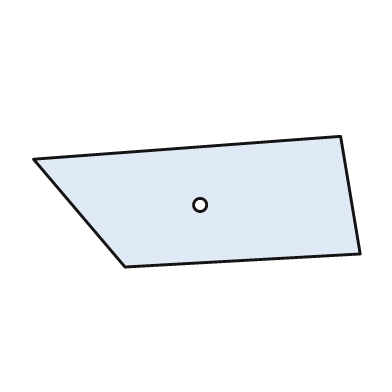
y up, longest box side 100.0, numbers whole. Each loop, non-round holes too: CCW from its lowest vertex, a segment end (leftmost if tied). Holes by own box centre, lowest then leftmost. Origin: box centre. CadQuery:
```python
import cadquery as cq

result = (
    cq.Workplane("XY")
    .moveTo(-22.0, -20.0)
    .lineTo(50.0, -16.0)
    .lineTo(44.0, 20.0)
    .lineTo(-50.0, 13.0)
    .close()
    .moveTo(1.0, -1.0)
    .circle(2.0)
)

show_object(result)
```